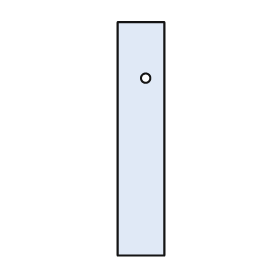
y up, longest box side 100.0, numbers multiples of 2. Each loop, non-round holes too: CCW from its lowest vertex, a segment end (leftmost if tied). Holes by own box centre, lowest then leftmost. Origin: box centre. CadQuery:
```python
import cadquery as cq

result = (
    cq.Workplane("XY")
    .moveTo(-10.0, -50.0)
    .lineTo(10.0, -50.0)
    .lineTo(10.0, 50.0)
    .lineTo(-10.0, 50.0)
    .close()
    .moveTo(2.0, 26.0)
    .circle(2.0)
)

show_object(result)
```